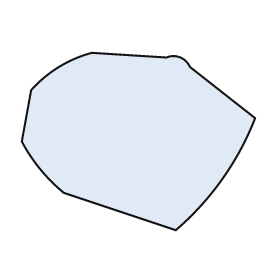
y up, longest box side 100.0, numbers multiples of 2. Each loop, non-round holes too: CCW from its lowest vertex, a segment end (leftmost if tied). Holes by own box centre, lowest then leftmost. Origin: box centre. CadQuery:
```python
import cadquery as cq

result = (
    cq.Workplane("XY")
    .moveTo(16.0, -38.0)
    .threePointArc((36.0, -16.0), (50.0, 10.0))
    .lineTo(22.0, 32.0)
    .threePointArc((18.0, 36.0), (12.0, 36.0))
    .lineTo(-20.0, 38.0)
    .threePointArc((-34.0, 32.0), (-46.0, 22.0))
    .lineTo(-50.0, 0.0)
    .threePointArc((-42.0, -12.0), (-32.0, -22.0))
    .close()
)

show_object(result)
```